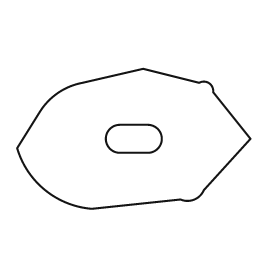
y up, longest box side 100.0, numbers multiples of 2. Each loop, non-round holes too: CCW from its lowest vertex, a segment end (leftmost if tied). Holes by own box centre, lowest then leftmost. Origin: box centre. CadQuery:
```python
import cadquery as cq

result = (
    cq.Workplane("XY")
    .moveTo(-18.0, -30.0)
    .lineTo(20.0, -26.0)
    .threePointArc((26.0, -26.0), (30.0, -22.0))
    .lineTo(50.0, 0.0)
    .lineTo(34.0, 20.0)
    .threePointArc((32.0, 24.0), (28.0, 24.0))
    .lineTo(4.0, 30.0)
    .lineTo(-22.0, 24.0)
    .threePointArc((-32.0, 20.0), (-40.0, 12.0))
    .lineTo(-50.0, -4.0)
    .threePointArc((-38.0, -22.0), (-18.0, -30.0))
    .close()
    .moveTo(-6.0, -6.0)
    .lineTo(6.0, -6.0)
    .threePointArc((12.0, 0.0), (6.0, 6.0))
    .lineTo(-6.0, 6.0)
    .threePointArc((-12.0, 0.0), (-6.0, -6.0))
    .close()
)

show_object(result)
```